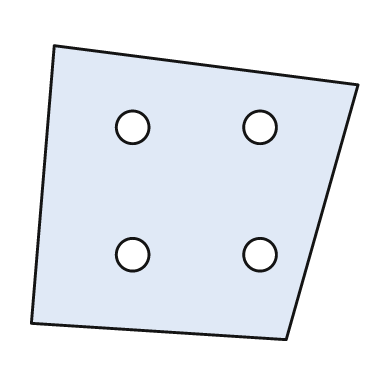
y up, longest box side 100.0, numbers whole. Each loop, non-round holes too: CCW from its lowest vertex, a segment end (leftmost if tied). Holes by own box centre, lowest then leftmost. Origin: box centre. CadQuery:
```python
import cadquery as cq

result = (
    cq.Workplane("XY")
    .moveTo(28.0, -45.0)
    .lineTo(50.0, 33.0)
    .lineTo(-43.0, 45.0)
    .lineTo(-50.0, -40.0)
    .close()
    .moveTo(-19.0, -19.0)
    .circle(5.0)
    .moveTo(20.0, -19.0)
    .circle(5.0)
    .moveTo(-19.0, 20.0)
    .circle(5.0)
    .moveTo(20.0, 20.0)
    .circle(5.0)
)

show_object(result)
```